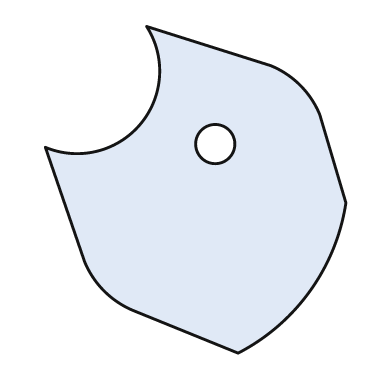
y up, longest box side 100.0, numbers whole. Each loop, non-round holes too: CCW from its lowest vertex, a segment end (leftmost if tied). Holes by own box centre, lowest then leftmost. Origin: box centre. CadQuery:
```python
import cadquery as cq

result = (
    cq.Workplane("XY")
    .moveTo(13.0, -50.0)
    .threePointArc((35.0, -31.0), (46.0, -4.0))
    .lineTo(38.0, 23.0)
    .threePointArc((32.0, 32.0), (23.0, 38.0))
    .lineTo(-15.0, 50.0)
    .threePointArc((-17.0, 20.0), (-46.0, 13.0))
    .lineTo(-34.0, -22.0)
    .threePointArc((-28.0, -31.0), (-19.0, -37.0))
    .close()
    .moveTo(6.0, 14.0)
    .circle(6.0)
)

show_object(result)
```